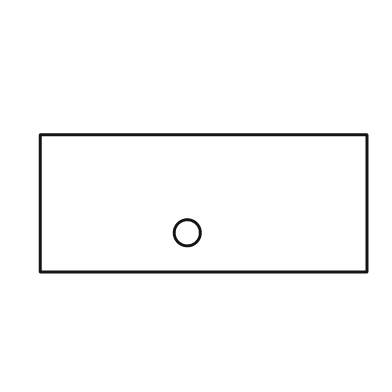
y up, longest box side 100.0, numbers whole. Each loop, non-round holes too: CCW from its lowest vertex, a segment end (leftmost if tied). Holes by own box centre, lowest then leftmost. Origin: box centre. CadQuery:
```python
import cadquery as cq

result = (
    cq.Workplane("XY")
    .moveTo(-50.0, -21.0)
    .lineTo(50.0, -21.0)
    .lineTo(50.0, 21.0)
    .lineTo(-50.0, 21.0)
    .close()
    .moveTo(-5.0, -9.0)
    .circle(4.0)
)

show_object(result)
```